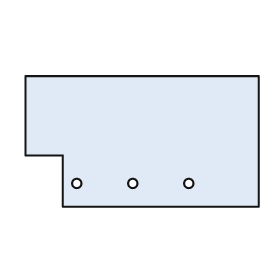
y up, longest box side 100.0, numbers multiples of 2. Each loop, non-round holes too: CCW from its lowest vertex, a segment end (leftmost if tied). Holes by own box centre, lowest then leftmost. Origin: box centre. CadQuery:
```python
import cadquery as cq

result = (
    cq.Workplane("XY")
    .moveTo(-34.0, -28.0)
    .lineTo(50.0, -28.0)
    .lineTo(50.0, 28.0)
    .lineTo(-50.0, 28.0)
    .lineTo(-50.0, -6.0)
    .lineTo(-34.0, -6.0)
    .close()
    .moveTo(-28.0, -18.0)
    .circle(2.0)
    .moveTo(-4.0, -18.0)
    .circle(2.0)
    .moveTo(20.0, -18.0)
    .circle(2.0)
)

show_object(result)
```